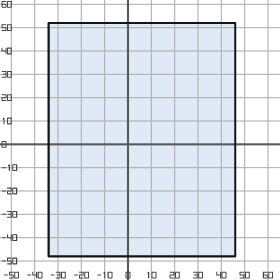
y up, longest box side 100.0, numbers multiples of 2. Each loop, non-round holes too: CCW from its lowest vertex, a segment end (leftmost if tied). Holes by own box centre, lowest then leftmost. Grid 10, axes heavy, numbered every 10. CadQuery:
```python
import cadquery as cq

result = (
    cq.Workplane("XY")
    .moveTo(-34.0, -48.0)
    .lineTo(46.0, -48.0)
    .lineTo(46.0, 52.0)
    .lineTo(-34.0, 52.0)
    .close()
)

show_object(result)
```